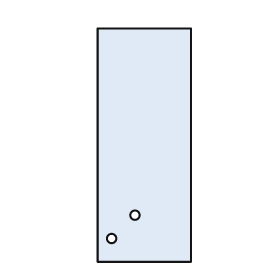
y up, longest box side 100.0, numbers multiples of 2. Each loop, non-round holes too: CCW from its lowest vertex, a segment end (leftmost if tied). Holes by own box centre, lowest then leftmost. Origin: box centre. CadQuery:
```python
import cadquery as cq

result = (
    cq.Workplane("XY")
    .moveTo(-20.0, -50.0)
    .lineTo(20.0, -50.0)
    .lineTo(20.0, 50.0)
    .lineTo(-20.0, 50.0)
    .close()
    .moveTo(-14.0, -40.0)
    .circle(2.0)
    .moveTo(-4.0, -30.0)
    .circle(2.0)
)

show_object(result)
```